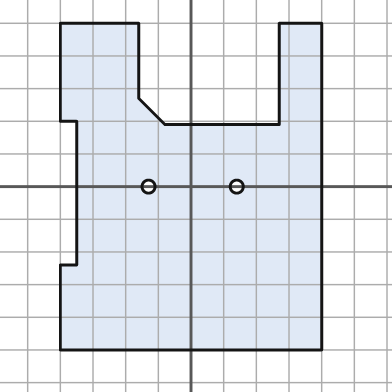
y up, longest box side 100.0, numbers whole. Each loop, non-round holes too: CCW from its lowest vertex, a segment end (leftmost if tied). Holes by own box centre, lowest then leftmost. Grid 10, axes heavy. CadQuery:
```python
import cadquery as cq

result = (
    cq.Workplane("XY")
    .moveTo(-40.0, -50.0)
    .lineTo(40.0, -50.0)
    .lineTo(40.0, 50.0)
    .lineTo(27.0, 50.0)
    .lineTo(27.0, 19.0)
    .lineTo(-8.0, 19.0)
    .lineTo(-16.0, 27.0)
    .lineTo(-16.0, 50.0)
    .lineTo(-40.0, 50.0)
    .lineTo(-40.0, 20.0)
    .lineTo(-35.0, 20.0)
    .lineTo(-35.0, -24.0)
    .lineTo(-40.0, -24.0)
    .close()
    .moveTo(-13.0, 0.0)
    .circle(2.0)
    .moveTo(14.0, 0.0)
    .circle(2.0)
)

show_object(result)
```